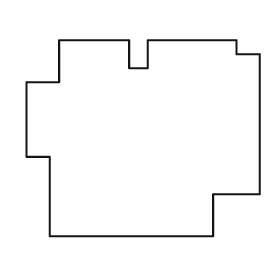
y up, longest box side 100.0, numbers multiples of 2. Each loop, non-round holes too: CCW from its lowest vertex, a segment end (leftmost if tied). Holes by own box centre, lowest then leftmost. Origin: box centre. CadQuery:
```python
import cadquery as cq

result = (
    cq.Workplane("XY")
    .moveTo(-40.0, -42.0)
    .lineTo(30.0, -42.0)
    .lineTo(30.0, -24.0)
    .lineTo(50.0, -24.0)
    .lineTo(50.0, 36.0)
    .lineTo(40.0, 36.0)
    .lineTo(40.0, 42.0)
    .lineTo(2.0, 42.0)
    .lineTo(2.0, 30.0)
    .lineTo(-6.0, 30.0)
    .lineTo(-6.0, 42.0)
    .lineTo(-36.0, 42.0)
    .lineTo(-36.0, 24.0)
    .lineTo(-50.0, 24.0)
    .lineTo(-50.0, -8.0)
    .lineTo(-40.0, -8.0)
    .close()
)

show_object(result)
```